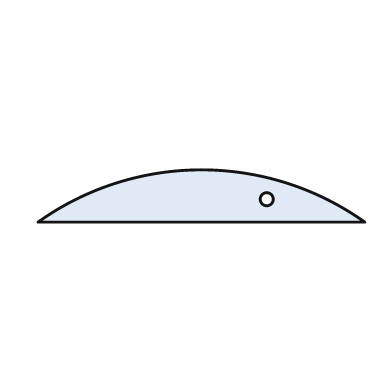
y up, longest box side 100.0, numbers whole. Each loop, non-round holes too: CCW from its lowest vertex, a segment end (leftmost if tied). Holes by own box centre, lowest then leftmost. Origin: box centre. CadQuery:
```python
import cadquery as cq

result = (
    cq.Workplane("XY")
    .moveTo(-50.0, -8.0)
    .lineTo(50.0, -8.0)
    .threePointArc((0.0, 8.0), (-50.0, -8.0))
    .close()
    .moveTo(20.0, -1.0)
    .circle(2.0)
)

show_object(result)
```